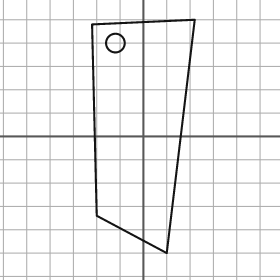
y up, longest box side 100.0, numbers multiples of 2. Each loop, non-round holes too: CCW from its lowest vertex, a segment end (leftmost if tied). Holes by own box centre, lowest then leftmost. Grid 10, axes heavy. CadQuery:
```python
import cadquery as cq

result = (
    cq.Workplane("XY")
    .moveTo(10.0, -50.0)
    .lineTo(22.0, 50.0)
    .lineTo(-22.0, 48.0)
    .lineTo(-20.0, -34.0)
    .close()
    .moveTo(-12.0, 40.0)
    .circle(4.0)
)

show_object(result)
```